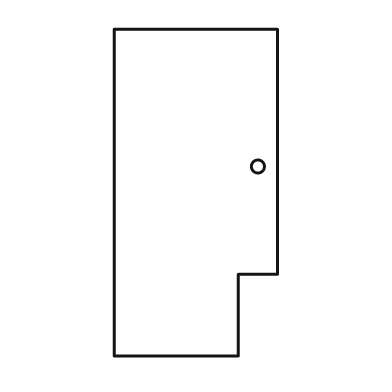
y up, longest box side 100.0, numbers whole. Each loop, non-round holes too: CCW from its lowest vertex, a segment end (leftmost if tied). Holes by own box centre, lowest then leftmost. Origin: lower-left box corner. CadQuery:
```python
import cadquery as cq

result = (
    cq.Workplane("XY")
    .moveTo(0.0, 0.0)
    .lineTo(38.0, 0.0)
    .lineTo(38.0, 25.0)
    .lineTo(50.0, 25.0)
    .lineTo(50.0, 100.0)
    .lineTo(0.0, 100.0)
    .close()
    .moveTo(44.0, 58.0)
    .circle(2.0)
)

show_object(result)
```